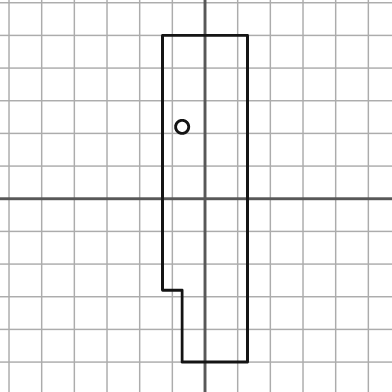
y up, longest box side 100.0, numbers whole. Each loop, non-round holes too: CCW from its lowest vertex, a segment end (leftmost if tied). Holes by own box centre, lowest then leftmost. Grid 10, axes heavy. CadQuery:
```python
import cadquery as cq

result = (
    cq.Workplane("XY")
    .moveTo(-7.0, -50.0)
    .lineTo(13.0, -50.0)
    .lineTo(13.0, 50.0)
    .lineTo(-13.0, 50.0)
    .lineTo(-13.0, -28.0)
    .lineTo(-7.0, -28.0)
    .close()
    .moveTo(-7.0, 22.0)
    .circle(2.0)
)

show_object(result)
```